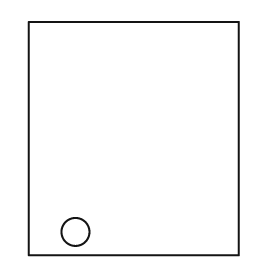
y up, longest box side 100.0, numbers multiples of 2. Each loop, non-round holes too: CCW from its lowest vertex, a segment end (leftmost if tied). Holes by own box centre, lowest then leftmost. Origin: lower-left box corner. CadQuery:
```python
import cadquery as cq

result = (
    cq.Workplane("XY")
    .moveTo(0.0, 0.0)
    .lineTo(90.0, 0.0)
    .lineTo(90.0, 100.0)
    .lineTo(0.0, 100.0)
    .close()
    .moveTo(20.0, 10.0)
    .circle(6.0)
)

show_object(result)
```